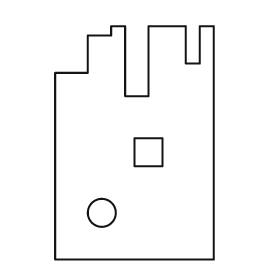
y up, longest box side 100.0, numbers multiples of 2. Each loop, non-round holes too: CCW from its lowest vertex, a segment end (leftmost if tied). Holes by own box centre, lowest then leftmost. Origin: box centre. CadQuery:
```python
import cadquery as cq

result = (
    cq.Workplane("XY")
    .moveTo(-34.0, -50.0)
    .lineTo(34.0, -50.0)
    .lineTo(34.0, 50.0)
    .lineTo(28.0, 50.0)
    .lineTo(28.0, 34.0)
    .lineTo(22.0, 34.0)
    .lineTo(22.0, 50.0)
    .lineTo(6.0, 50.0)
    .lineTo(6.0, 20.0)
    .lineTo(-4.0, 20.0)
    .lineTo(-4.0, 50.0)
    .lineTo(-10.0, 50.0)
    .lineTo(-10.0, 46.0)
    .lineTo(-20.0, 46.0)
    .lineTo(-20.0, 30.0)
    .lineTo(-34.0, 30.0)
    .close()
    .moveTo(-14.0, -30.0)
    .circle(6.0)
    .moveTo(0.0, -10.0)
    .lineTo(12.0, -10.0)
    .lineTo(12.0, 2.0)
    .lineTo(0.0, 2.0)
    .close()
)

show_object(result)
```